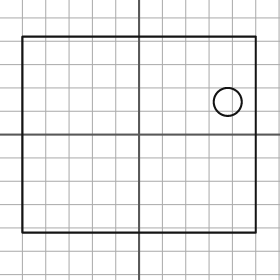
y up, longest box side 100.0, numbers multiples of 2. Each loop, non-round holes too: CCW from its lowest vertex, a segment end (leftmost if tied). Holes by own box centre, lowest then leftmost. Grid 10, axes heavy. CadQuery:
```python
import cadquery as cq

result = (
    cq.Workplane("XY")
    .moveTo(-50.0, -42.0)
    .lineTo(50.0, -42.0)
    .lineTo(50.0, 42.0)
    .lineTo(-50.0, 42.0)
    .close()
    .moveTo(38.0, 14.0)
    .circle(6.0)
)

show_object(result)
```